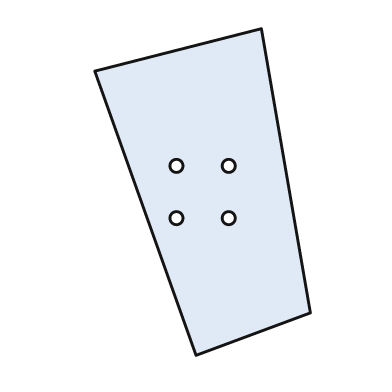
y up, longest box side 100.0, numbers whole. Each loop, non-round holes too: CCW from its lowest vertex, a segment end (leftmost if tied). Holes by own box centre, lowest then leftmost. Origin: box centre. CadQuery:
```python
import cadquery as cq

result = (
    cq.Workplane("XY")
    .moveTo(-2.0, -50.0)
    .lineTo(33.0, -37.0)
    .lineTo(18.0, 50.0)
    .lineTo(-33.0, 37.0)
    .close()
    .moveTo(-8.0, -8.0)
    .circle(2.0)
    .moveTo(8.0, -8.0)
    .circle(2.0)
    .moveTo(-8.0, 8.0)
    .circle(2.0)
    .moveTo(8.0, 8.0)
    .circle(2.0)
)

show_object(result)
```